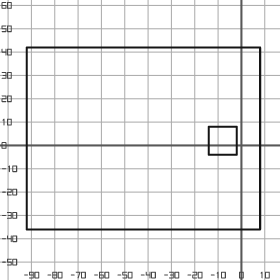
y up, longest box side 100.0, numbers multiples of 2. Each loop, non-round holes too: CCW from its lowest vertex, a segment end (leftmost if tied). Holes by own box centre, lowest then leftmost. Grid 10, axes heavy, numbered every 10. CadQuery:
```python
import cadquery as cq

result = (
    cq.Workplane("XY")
    .moveTo(-92.0, -36.0)
    .lineTo(8.0, -36.0)
    .lineTo(8.0, 42.0)
    .lineTo(-92.0, 42.0)
    .close()
    .moveTo(-14.0, -4.0)
    .lineTo(-2.0, -4.0)
    .lineTo(-2.0, 8.0)
    .lineTo(-14.0, 8.0)
    .close()
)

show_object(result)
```